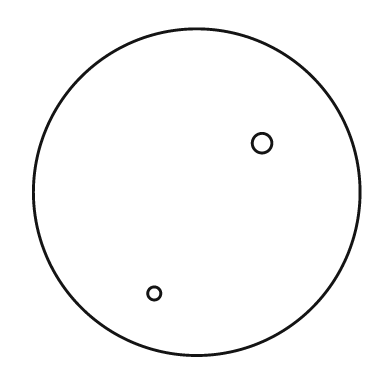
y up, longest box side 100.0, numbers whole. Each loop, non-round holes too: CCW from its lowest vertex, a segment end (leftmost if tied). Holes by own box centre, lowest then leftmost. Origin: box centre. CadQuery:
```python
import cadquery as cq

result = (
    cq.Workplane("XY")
    .moveTo(0.0, 0.0)
    .circle(50.0)
    .moveTo(-13.0, -31.0)
    .circle(2.0)
    .moveTo(20.0, 15.0)
    .circle(3.0)
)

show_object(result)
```